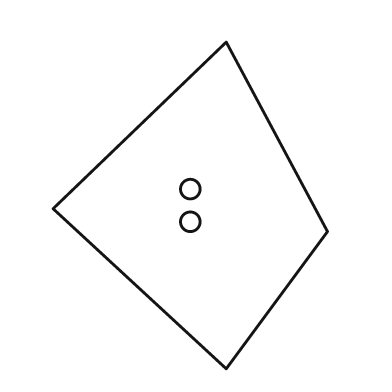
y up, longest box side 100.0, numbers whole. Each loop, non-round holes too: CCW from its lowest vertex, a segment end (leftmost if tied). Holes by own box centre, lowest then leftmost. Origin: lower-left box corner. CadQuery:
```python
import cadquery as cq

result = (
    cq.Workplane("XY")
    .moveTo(53.0, 0.0)
    .lineTo(84.0, 42.0)
    .lineTo(53.0, 100.0)
    .lineTo(0.0, 49.0)
    .close()
    .moveTo(42.0, 45.0)
    .circle(3.0)
    .moveTo(42.0, 55.0)
    .circle(3.0)
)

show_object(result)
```